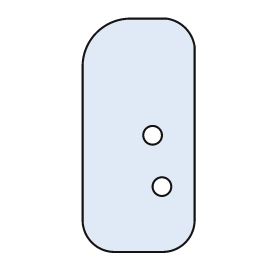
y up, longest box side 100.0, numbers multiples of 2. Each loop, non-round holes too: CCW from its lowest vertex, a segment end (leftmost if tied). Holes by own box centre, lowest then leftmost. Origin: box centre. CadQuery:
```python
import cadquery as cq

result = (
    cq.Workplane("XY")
    .moveTo(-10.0, -50.0)
    .lineTo(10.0, -50.0)
    .threePointArc((20.0, -46.0), (24.0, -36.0))
    .lineTo(24.0, 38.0)
    .threePointArc((20.0, 46.0), (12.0, 50.0))
    .lineTo(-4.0, 50.0)
    .threePointArc((-18.0, 44.0), (-24.0, 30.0))
    .lineTo(-24.0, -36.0)
    .threePointArc((-20.0, -46.0), (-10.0, -50.0))
    .close()
    .moveTo(10.0, -22.0)
    .circle(4.0)
    .moveTo(6.0, 0.0)
    .circle(4.0)
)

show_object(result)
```